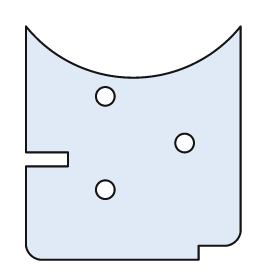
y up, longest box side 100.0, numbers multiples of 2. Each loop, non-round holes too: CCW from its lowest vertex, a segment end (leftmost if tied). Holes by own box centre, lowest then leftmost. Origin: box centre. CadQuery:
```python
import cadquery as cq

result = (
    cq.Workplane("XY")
    .moveTo(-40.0, -50.0)
    .lineTo(28.0, -50.0)
    .lineTo(28.0, -44.0)
    .lineTo(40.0, -44.0)
    .threePointArc((44.0, -42.0), (46.0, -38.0))
    .lineTo(46.0, 50.0)
    .threePointArc((0.0, 28.0), (-46.0, 50.0))
    .lineTo(-46.0, -4.0)
    .lineTo(-28.0, -4.0)
    .lineTo(-28.0, -10.0)
    .lineTo(-46.0, -10.0)
    .lineTo(-46.0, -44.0)
    .threePointArc((-44.0, -48.0), (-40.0, -50.0))
    .close()
    .moveTo(-12.0, -20.0)
    .circle(4.0)
    .moveTo(22.0, 0.0)
    .circle(4.0)
    .moveTo(-12.0, 20.0)
    .circle(4.0)
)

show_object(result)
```